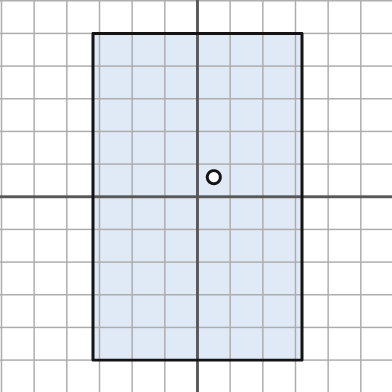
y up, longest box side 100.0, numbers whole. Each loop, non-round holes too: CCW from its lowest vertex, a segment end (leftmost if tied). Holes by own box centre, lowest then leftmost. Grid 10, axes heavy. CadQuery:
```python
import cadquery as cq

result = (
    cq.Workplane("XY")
    .moveTo(-32.0, -50.0)
    .lineTo(32.0, -50.0)
    .lineTo(32.0, 50.0)
    .lineTo(-32.0, 50.0)
    .close()
    .moveTo(5.0, 6.0)
    .circle(2.0)
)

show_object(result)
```